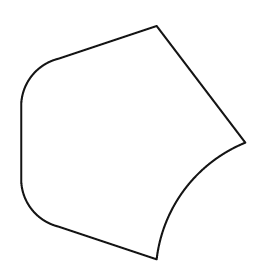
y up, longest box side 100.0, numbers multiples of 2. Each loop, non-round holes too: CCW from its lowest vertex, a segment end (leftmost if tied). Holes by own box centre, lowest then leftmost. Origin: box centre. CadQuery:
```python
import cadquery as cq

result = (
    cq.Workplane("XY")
    .moveTo(10.0, -50.0)
    .threePointArc((22.0, -20.0), (48.0, 0.0))
    .lineTo(10.0, 50.0)
    .lineTo(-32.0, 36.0)
    .threePointArc((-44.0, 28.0), (-48.0, 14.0))
    .lineTo(-48.0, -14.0)
    .threePointArc((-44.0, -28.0), (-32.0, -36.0))
    .close()
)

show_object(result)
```